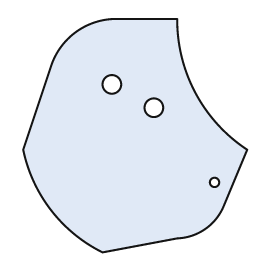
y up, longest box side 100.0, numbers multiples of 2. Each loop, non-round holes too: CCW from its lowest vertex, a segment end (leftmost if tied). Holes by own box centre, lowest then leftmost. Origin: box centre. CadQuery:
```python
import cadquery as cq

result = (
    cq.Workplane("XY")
    .moveTo(-14.0, -50.0)
    .lineTo(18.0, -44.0)
    .threePointArc((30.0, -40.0), (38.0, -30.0))
    .lineTo(48.0, -6.0)
    .threePointArc((26.0, 18.0), (18.0, 50.0))
    .lineTo(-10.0, 50.0)
    .threePointArc((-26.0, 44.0), (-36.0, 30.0))
    .lineTo(-48.0, -6.0)
    .threePointArc((-36.0, -32.0), (-14.0, -50.0))
    .close()
    .moveTo(34.0, -20.0)
    .circle(2.0)
    .moveTo(8.0, 12.0)
    .circle(4.0)
    .moveTo(-10.0, 22.0)
    .circle(4.0)
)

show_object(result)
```